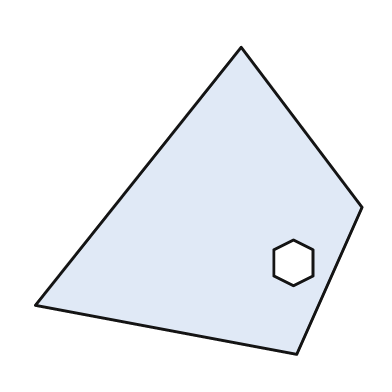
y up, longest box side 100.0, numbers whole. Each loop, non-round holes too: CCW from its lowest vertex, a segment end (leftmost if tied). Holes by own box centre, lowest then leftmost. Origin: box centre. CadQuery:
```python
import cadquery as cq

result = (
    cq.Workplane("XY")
    .moveTo(30.0, -47.0)
    .lineTo(50.0, -2.0)
    .lineTo(13.0, 47.0)
    .lineTo(-50.0, -32.0)
    .close()
    .moveTo(29.0, -26.0)
    .lineTo(35.0, -23.0)
    .lineTo(35.0, -15.0)
    .lineTo(29.0, -12.0)
    .lineTo(23.0, -15.0)
    .lineTo(23.0, -23.0)
    .close()
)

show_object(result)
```